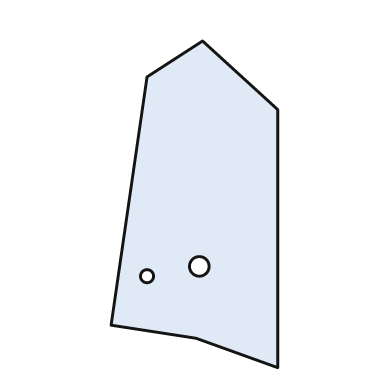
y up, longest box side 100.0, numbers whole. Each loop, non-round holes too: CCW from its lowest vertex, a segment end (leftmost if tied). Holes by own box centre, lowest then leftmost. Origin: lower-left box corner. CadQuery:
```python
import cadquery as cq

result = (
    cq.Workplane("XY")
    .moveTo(51.0, 0.0)
    .lineTo(51.0, 79.0)
    .lineTo(28.0, 100.0)
    .lineTo(11.0, 89.0)
    .lineTo(0.0, 13.0)
    .lineTo(26.0, 9.0)
    .close()
    .moveTo(11.0, 28.0)
    .circle(2.0)
    .moveTo(27.0, 31.0)
    .circle(3.0)
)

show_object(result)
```